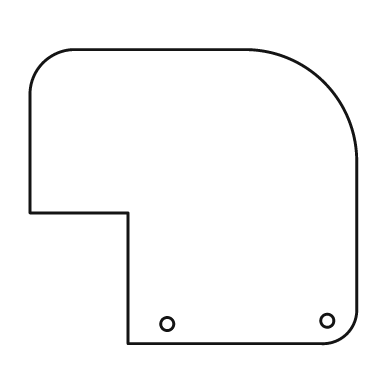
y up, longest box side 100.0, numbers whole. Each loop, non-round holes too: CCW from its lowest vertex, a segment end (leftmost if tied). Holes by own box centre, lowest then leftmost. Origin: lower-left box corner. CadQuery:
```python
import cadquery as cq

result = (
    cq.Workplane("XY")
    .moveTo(30.0, 0.0)
    .lineTo(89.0, 0.0)
    .threePointArc((97.0, 3.0), (100.0, 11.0))
    .lineTo(100.0, 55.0)
    .threePointArc((90.0, 80.0), (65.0, 90.0))
    .lineTo(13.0, 90.0)
    .threePointArc((4.0, 86.0), (0.0, 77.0))
    .lineTo(0.0, 40.0)
    .lineTo(30.0, 40.0)
    .close()
    .moveTo(42.0, 6.0)
    .circle(2.0)
    .moveTo(91.0, 7.0)
    .circle(2.0)
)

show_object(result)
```